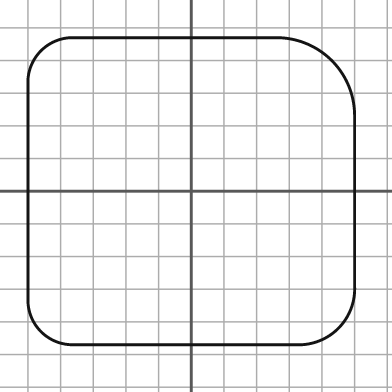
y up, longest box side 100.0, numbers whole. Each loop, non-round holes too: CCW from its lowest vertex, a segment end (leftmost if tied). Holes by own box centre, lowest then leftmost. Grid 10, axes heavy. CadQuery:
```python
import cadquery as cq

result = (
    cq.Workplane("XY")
    .moveTo(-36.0, -47.0)
    .lineTo(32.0, -47.0)
    .threePointArc((45.0, -42.0), (50.0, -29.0))
    .lineTo(50.0, 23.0)
    .threePointArc((43.0, 40.0), (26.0, 47.0))
    .lineTo(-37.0, 47.0)
    .threePointArc((-46.0, 43.0), (-50.0, 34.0))
    .lineTo(-50.0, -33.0)
    .threePointArc((-46.0, -43.0), (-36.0, -47.0))
    .close()
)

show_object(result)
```